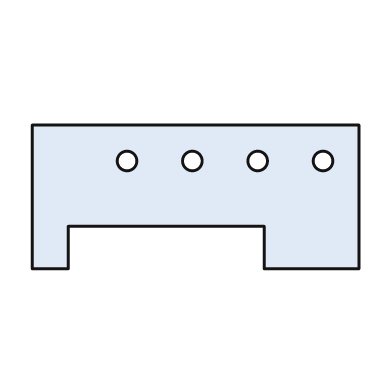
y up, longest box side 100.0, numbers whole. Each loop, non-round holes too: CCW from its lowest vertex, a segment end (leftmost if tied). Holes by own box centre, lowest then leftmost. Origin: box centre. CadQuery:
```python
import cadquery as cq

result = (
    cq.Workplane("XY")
    .moveTo(-50.0, -22.0)
    .lineTo(-39.0, -22.0)
    .lineTo(-39.0, -9.0)
    .lineTo(21.0, -9.0)
    .lineTo(21.0, -22.0)
    .lineTo(50.0, -22.0)
    .lineTo(50.0, 22.0)
    .lineTo(-50.0, 22.0)
    .close()
    .moveTo(-21.0, 11.0)
    .circle(3.0)
    .moveTo(-1.0, 11.0)
    .circle(3.0)
    .moveTo(19.0, 11.0)
    .circle(3.0)
    .moveTo(39.0, 11.0)
    .circle(3.0)
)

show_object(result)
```